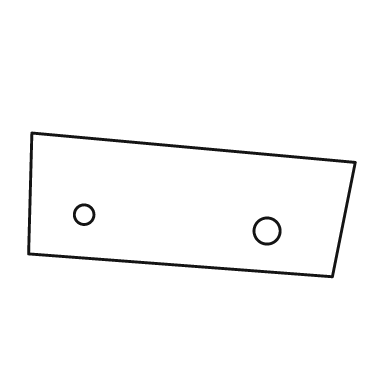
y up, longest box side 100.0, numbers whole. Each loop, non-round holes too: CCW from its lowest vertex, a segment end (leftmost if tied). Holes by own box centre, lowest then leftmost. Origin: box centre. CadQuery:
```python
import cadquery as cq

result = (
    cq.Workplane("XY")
    .moveTo(43.0, -22.0)
    .lineTo(50.0, 13.0)
    .lineTo(-49.0, 22.0)
    .lineTo(-50.0, -15.0)
    .close()
    .moveTo(23.0, -8.0)
    .circle(4.0)
    .moveTo(-33.0, -3.0)
    .circle(3.0)
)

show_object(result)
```